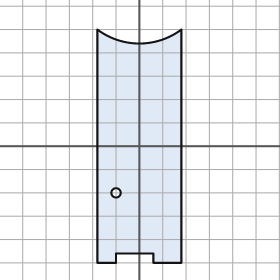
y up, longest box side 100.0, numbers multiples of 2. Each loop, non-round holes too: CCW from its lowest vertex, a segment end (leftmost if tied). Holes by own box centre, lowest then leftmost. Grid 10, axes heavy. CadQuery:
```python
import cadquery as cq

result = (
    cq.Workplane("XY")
    .moveTo(-18.0, -50.0)
    .lineTo(-10.0, -50.0)
    .lineTo(-10.0, -46.0)
    .lineTo(6.0, -46.0)
    .lineTo(6.0, -50.0)
    .lineTo(18.0, -50.0)
    .lineTo(18.0, 50.0)
    .threePointArc((0.0, 44.0), (-18.0, 50.0))
    .close()
    .moveTo(-10.0, -20.0)
    .circle(2.0)
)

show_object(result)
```